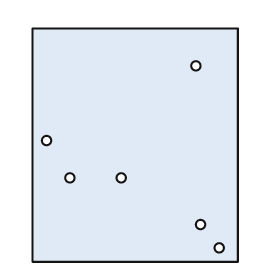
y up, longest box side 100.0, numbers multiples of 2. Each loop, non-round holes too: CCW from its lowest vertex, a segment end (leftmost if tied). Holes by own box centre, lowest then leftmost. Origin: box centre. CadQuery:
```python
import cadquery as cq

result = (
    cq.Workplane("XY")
    .moveTo(-44.0, -50.0)
    .lineTo(44.0, -50.0)
    .lineTo(44.0, 50.0)
    .lineTo(-44.0, 50.0)
    .close()
    .moveTo(36.0, -44.0)
    .circle(2.0)
    .moveTo(28.0, -34.0)
    .circle(2.0)
    .moveTo(-28.0, -14.0)
    .circle(2.0)
    .moveTo(-6.0, -14.0)
    .circle(2.0)
    .moveTo(-38.0, 2.0)
    .circle(2.0)
    .moveTo(26.0, 34.0)
    .circle(2.0)
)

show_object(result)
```